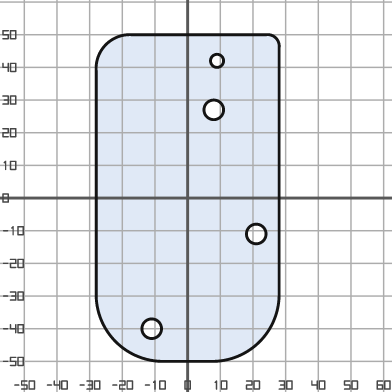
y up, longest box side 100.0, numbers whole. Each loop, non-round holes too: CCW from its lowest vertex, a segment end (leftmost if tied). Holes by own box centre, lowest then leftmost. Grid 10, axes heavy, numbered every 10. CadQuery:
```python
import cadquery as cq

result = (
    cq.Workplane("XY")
    .moveTo(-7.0, -50.0)
    .lineTo(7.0, -50.0)
    .threePointArc((22.0, -44.0), (28.0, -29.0))
    .lineTo(28.0, 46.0)
    .threePointArc((27.0, 49.0), (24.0, 50.0))
    .lineTo(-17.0, 50.0)
    .threePointArc((-25.0, 47.0), (-28.0, 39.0))
    .lineTo(-28.0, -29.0)
    .threePointArc((-22.0, -44.0), (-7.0, -50.0))
    .close()
    .moveTo(-11.0, -40.0)
    .circle(3.0)
    .moveTo(21.0, -11.0)
    .circle(3.0)
    .moveTo(8.0, 27.0)
    .circle(3.0)
    .moveTo(9.0, 42.0)
    .circle(2.0)
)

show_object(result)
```